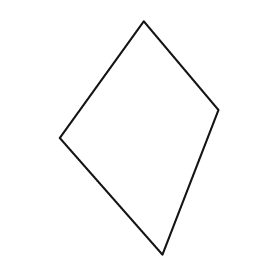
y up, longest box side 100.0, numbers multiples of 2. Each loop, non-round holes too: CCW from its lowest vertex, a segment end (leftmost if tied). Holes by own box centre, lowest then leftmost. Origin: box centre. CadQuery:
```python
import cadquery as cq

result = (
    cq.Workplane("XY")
    .moveTo(10.0, -50.0)
    .lineTo(34.0, 12.0)
    .lineTo(2.0, 50.0)
    .lineTo(-34.0, 0.0)
    .close()
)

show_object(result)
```